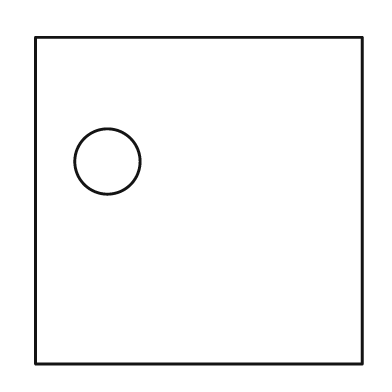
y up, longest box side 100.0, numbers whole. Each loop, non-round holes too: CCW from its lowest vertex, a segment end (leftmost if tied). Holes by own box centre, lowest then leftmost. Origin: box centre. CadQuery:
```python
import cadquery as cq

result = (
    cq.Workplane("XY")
    .moveTo(-50.0, -50.0)
    .lineTo(50.0, -50.0)
    .lineTo(50.0, 50.0)
    .lineTo(-50.0, 50.0)
    .close()
    .moveTo(-28.0, 12.0)
    .circle(10.0)
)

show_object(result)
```